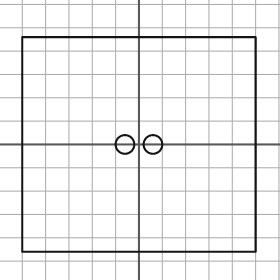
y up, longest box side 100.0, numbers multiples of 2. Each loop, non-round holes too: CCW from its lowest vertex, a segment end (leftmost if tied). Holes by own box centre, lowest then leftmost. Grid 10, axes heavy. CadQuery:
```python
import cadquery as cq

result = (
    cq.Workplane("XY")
    .moveTo(-50.0, -46.0)
    .lineTo(50.0, -46.0)
    .lineTo(50.0, 46.0)
    .lineTo(-50.0, 46.0)
    .close()
    .moveTo(-6.0, 0.0)
    .circle(4.0)
    .moveTo(6.0, 0.0)
    .circle(4.0)
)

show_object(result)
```